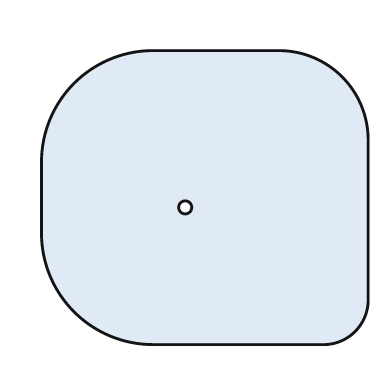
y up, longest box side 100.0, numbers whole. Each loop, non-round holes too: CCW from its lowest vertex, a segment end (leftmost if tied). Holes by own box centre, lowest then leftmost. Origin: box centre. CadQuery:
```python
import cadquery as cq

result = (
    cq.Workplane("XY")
    .moveTo(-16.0, -45.0)
    .lineTo(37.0, -45.0)
    .threePointArc((46.0, -41.0), (50.0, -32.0))
    .lineTo(50.0, 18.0)
    .threePointArc((42.0, 37.0), (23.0, 45.0))
    .lineTo(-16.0, 45.0)
    .threePointArc((-40.0, 35.0), (-50.0, 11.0))
    .lineTo(-50.0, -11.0)
    .threePointArc((-40.0, -35.0), (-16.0, -45.0))
    .close()
    .moveTo(-6.0, -3.0)
    .circle(2.0)
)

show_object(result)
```